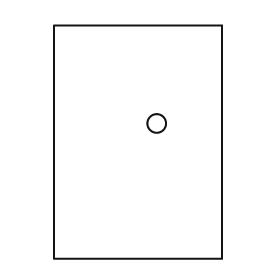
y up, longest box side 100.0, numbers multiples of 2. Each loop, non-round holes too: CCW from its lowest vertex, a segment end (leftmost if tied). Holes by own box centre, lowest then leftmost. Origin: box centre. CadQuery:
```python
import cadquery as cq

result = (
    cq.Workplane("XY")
    .moveTo(-36.0, -50.0)
    .lineTo(36.0, -50.0)
    .lineTo(36.0, 50.0)
    .lineTo(-36.0, 50.0)
    .close()
    .moveTo(8.0, 8.0)
    .circle(4.0)
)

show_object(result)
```